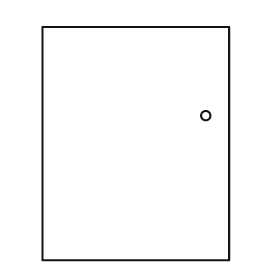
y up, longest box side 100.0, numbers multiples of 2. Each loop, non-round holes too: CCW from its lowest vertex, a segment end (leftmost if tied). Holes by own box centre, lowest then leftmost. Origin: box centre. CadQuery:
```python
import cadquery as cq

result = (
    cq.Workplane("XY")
    .moveTo(-40.0, -50.0)
    .lineTo(40.0, -50.0)
    .lineTo(40.0, 50.0)
    .lineTo(-40.0, 50.0)
    .close()
    .moveTo(30.0, 12.0)
    .circle(2.0)
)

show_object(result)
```